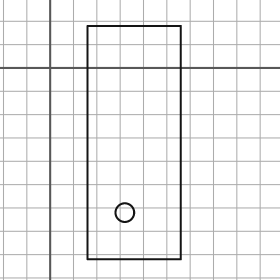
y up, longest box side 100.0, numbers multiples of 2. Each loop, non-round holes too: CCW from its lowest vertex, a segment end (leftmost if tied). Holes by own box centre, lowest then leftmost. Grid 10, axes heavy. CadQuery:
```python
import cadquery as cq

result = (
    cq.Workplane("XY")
    .moveTo(16.0, -82.0)
    .lineTo(56.0, -82.0)
    .lineTo(56.0, 18.0)
    .lineTo(16.0, 18.0)
    .close()
    .moveTo(32.0, -62.0)
    .circle(4.0)
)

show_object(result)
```